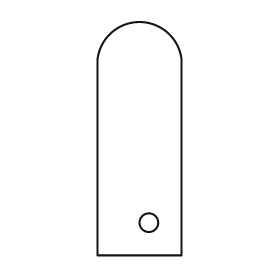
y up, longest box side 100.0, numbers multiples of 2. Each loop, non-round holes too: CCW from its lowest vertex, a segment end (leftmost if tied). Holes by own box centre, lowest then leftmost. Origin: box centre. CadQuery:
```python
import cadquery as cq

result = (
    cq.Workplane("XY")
    .moveTo(-18.0, -50.0)
    .lineTo(18.0, -50.0)
    .lineTo(18.0, 34.0)
    .threePointArc((0.0, 50.0), (-18.0, 34.0))
    .close()
    .moveTo(4.0, -36.0)
    .circle(4.0)
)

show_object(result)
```